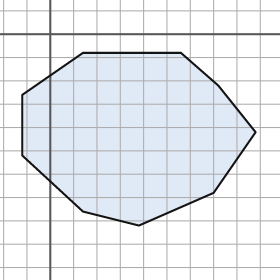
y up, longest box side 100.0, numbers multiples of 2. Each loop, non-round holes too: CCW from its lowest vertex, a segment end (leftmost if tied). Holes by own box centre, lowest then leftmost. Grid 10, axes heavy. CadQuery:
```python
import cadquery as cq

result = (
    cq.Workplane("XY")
    .moveTo(38.0, -82.0)
    .lineTo(70.0, -68.0)
    .lineTo(88.0, -42.0)
    .lineTo(72.0, -22.0)
    .lineTo(56.0, -8.0)
    .lineTo(14.0, -8.0)
    .lineTo(-12.0, -26.0)
    .lineTo(-12.0, -52.0)
    .lineTo(14.0, -76.0)
    .close()
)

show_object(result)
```